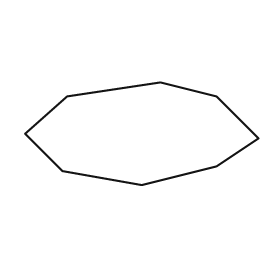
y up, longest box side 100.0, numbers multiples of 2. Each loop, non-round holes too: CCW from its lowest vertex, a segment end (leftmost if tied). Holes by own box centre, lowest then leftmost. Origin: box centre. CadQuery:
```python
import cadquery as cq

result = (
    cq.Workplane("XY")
    .moveTo(0.0, -22.0)
    .lineTo(32.0, -14.0)
    .lineTo(50.0, -2.0)
    .lineTo(32.0, 16.0)
    .lineTo(8.0, 22.0)
    .lineTo(-32.0, 16.0)
    .lineTo(-50.0, 0.0)
    .lineTo(-34.0, -16.0)
    .close()
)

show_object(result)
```